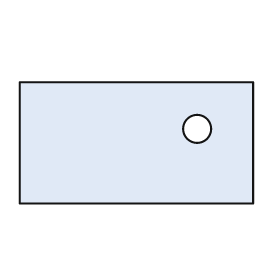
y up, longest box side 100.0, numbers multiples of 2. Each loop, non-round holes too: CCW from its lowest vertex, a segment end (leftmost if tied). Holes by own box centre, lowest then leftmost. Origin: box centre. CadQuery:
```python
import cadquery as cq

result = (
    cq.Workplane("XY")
    .moveTo(-50.0, -26.0)
    .lineTo(50.0, -26.0)
    .lineTo(50.0, 26.0)
    .lineTo(-50.0, 26.0)
    .close()
    .moveTo(26.0, 6.0)
    .circle(6.0)
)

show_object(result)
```